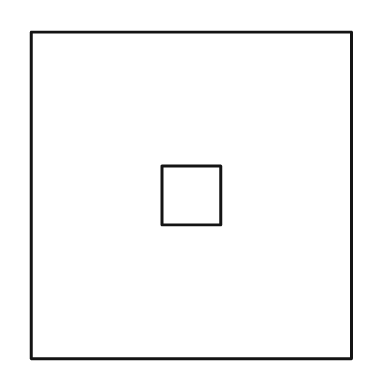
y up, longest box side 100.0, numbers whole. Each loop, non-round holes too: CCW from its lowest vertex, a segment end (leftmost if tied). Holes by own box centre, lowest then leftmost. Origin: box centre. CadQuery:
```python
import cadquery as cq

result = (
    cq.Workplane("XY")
    .moveTo(-49.0, -50.0)
    .lineTo(49.0, -50.0)
    .lineTo(49.0, 50.0)
    .lineTo(-49.0, 50.0)
    .close()
    .moveTo(-9.0, -9.0)
    .lineTo(9.0, -9.0)
    .lineTo(9.0, 9.0)
    .lineTo(-9.0, 9.0)
    .close()
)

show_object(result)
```